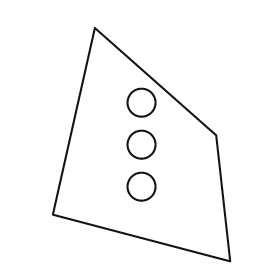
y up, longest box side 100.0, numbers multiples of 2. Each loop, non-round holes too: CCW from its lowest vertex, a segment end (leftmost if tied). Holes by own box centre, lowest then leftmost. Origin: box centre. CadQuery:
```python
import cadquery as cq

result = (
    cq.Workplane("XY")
    .moveTo(38.0, -50.0)
    .lineTo(32.0, 4.0)
    .lineTo(-20.0, 50.0)
    .lineTo(-38.0, -30.0)
    .close()
    .moveTo(0.0, -18.0)
    .circle(6.0)
    .moveTo(0.0, 0.0)
    .circle(6.0)
    .moveTo(0.0, 18.0)
    .circle(6.0)
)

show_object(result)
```